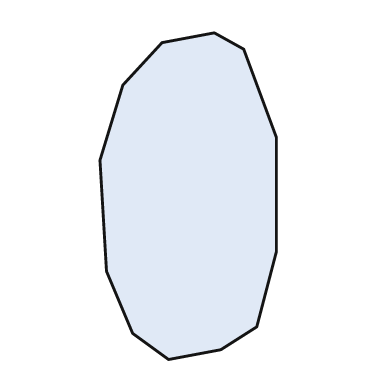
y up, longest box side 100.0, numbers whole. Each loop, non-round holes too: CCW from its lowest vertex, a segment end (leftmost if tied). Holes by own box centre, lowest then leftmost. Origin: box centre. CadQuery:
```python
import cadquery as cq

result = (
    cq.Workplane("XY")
    .moveTo(-6.0, -50.0)
    .lineTo(10.0, -47.0)
    .lineTo(21.0, -40.0)
    .lineTo(27.0, -17.0)
    .lineTo(27.0, 18.0)
    .lineTo(17.0, 45.0)
    .lineTo(8.0, 50.0)
    .lineTo(-8.0, 47.0)
    .lineTo(-20.0, 34.0)
    .lineTo(-27.0, 11.0)
    .lineTo(-25.0, -23.0)
    .lineTo(-17.0, -42.0)
    .close()
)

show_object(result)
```